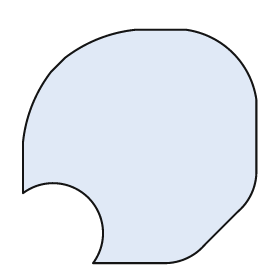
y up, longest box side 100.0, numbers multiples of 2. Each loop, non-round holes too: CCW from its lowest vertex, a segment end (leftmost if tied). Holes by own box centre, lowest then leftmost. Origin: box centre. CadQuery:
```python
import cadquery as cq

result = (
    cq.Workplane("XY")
    .moveTo(-20.0, -50.0)
    .lineTo(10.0, -50.0)
    .threePointArc((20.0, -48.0), (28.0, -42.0))
    .lineTo(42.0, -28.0)
    .threePointArc((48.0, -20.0), (50.0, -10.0))
    .lineTo(50.0, 20.0)
    .threePointArc((40.0, 40.0), (20.0, 50.0))
    .lineTo(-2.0, 50.0)
    .threePointArc((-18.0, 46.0), (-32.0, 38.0))
    .lineTo(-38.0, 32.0)
    .threePointArc((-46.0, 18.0), (-50.0, 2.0))
    .lineTo(-50.0, -20.0)
    .threePointArc((-22.0, -22.0), (-20.0, -50.0))
    .close()
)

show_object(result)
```